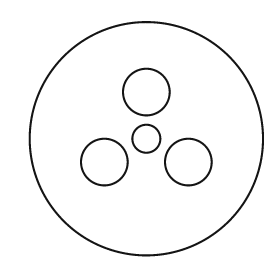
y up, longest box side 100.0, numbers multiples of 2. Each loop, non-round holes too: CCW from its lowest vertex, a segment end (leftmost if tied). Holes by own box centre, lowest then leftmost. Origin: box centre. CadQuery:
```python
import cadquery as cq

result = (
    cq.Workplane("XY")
    .moveTo(0.0, 0.0)
    .circle(50.0)
    .moveTo(-18.0, -10.0)
    .circle(10.0)
    .moveTo(18.0, -10.0)
    .circle(10.0)
    .moveTo(0.0, 0.0)
    .circle(6.0)
    .moveTo(0.0, 20.0)
    .circle(10.0)
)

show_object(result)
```